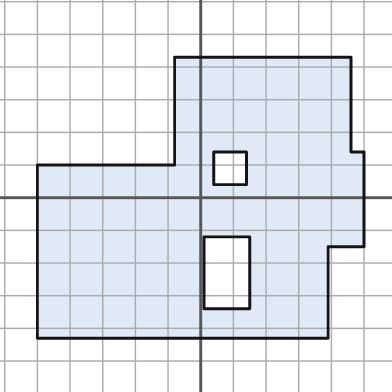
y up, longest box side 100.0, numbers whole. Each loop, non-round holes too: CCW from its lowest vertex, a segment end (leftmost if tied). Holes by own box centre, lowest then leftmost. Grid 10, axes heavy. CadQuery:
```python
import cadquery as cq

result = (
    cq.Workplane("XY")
    .moveTo(-50.0, -43.0)
    .lineTo(39.0, -43.0)
    .lineTo(39.0, -15.0)
    .lineTo(50.0, -15.0)
    .lineTo(50.0, 14.0)
    .lineTo(46.0, 14.0)
    .lineTo(46.0, 43.0)
    .lineTo(-8.0, 43.0)
    .lineTo(-8.0, 10.0)
    .lineTo(-50.0, 10.0)
    .close()
    .moveTo(1.0, -34.0)
    .lineTo(15.0, -34.0)
    .lineTo(15.0, -12.0)
    .lineTo(1.0, -12.0)
    .close()
    .moveTo(4.0, 4.0)
    .lineTo(14.0, 4.0)
    .lineTo(14.0, 14.0)
    .lineTo(4.0, 14.0)
    .close()
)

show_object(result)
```